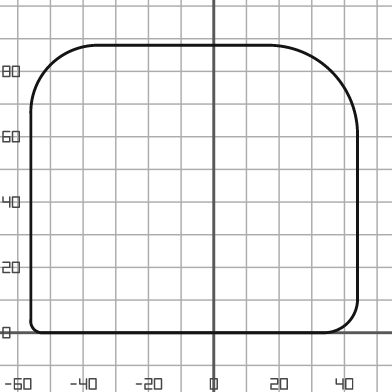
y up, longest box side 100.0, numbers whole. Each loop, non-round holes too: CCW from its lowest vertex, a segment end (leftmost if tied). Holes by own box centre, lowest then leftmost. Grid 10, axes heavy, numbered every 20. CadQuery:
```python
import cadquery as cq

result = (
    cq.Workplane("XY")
    .moveTo(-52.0, 0.0)
    .lineTo(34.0, 0.0)
    .threePointArc((41.0, 3.0), (44.0, 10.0))
    .lineTo(44.0, 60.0)
    .threePointArc((36.0, 80.0), (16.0, 88.0))
    .lineTo(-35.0, 88.0)
    .threePointArc((-50.0, 82.0), (-56.0, 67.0))
    .lineTo(-56.0, 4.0)
    .threePointArc((-55.0, 1.0), (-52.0, 0.0))
    .close()
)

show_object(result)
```